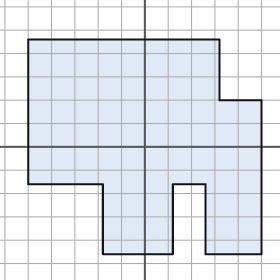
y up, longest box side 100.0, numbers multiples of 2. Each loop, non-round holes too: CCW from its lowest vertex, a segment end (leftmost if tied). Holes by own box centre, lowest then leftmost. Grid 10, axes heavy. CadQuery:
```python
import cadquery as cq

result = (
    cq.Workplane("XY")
    .moveTo(-18.0, -46.0)
    .lineTo(12.0, -46.0)
    .lineTo(12.0, -16.0)
    .lineTo(26.0, -16.0)
    .lineTo(26.0, -46.0)
    .lineTo(50.0, -46.0)
    .lineTo(50.0, 20.0)
    .lineTo(32.0, 20.0)
    .lineTo(32.0, 46.0)
    .lineTo(-50.0, 46.0)
    .lineTo(-50.0, -16.0)
    .lineTo(-18.0, -16.0)
    .close()
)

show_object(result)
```